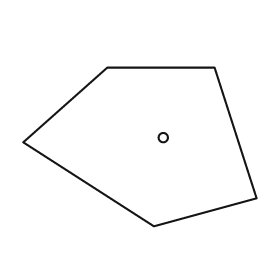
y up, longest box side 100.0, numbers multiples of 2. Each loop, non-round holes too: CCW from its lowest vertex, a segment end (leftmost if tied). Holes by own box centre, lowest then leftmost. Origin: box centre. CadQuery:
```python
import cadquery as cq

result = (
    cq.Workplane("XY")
    .moveTo(6.0, -34.0)
    .lineTo(50.0, -22.0)
    .lineTo(32.0, 34.0)
    .lineTo(-14.0, 34.0)
    .lineTo(-50.0, 2.0)
    .close()
    .moveTo(10.0, 4.0)
    .circle(2.0)
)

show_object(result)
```